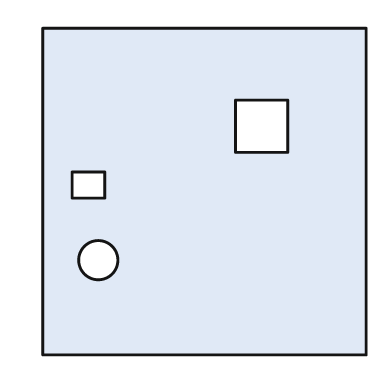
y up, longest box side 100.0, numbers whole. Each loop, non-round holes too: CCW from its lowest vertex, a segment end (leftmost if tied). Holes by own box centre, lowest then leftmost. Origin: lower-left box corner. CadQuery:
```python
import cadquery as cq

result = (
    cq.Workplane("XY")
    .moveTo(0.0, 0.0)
    .lineTo(99.0, 0.0)
    .lineTo(99.0, 100.0)
    .lineTo(0.0, 100.0)
    .close()
    .moveTo(17.0, 29.0)
    .circle(6.0)
    .moveTo(9.0, 48.0)
    .lineTo(19.0, 48.0)
    .lineTo(19.0, 56.0)
    .lineTo(9.0, 56.0)
    .close()
    .moveTo(59.0, 62.0)
    .lineTo(75.0, 62.0)
    .lineTo(75.0, 78.0)
    .lineTo(59.0, 78.0)
    .close()
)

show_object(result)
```